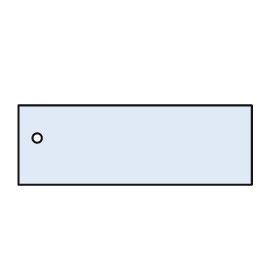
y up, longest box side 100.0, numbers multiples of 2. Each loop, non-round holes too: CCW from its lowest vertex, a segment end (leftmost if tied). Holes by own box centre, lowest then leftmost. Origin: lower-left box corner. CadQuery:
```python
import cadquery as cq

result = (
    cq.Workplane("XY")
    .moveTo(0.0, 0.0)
    .lineTo(100.0, 0.0)
    .lineTo(100.0, 34.0)
    .lineTo(0.0, 34.0)
    .close()
    .moveTo(8.0, 20.0)
    .circle(2.0)
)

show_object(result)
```